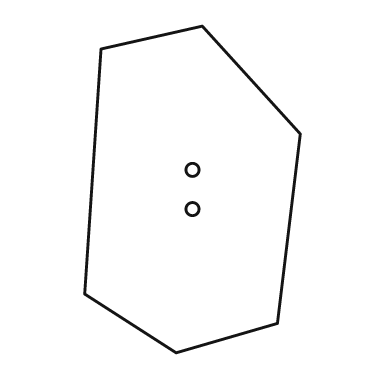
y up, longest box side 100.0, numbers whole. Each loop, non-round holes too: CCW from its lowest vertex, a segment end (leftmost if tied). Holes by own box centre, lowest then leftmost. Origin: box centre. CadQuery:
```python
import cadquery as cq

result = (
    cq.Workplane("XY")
    .moveTo(-5.0, -50.0)
    .lineTo(26.0, -41.0)
    .lineTo(33.0, 17.0)
    .lineTo(3.0, 50.0)
    .lineTo(-28.0, 43.0)
    .lineTo(-33.0, -32.0)
    .close()
    .moveTo(0.0, -6.0)
    .circle(2.0)
    .moveTo(0.0, 6.0)
    .circle(2.0)
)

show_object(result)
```